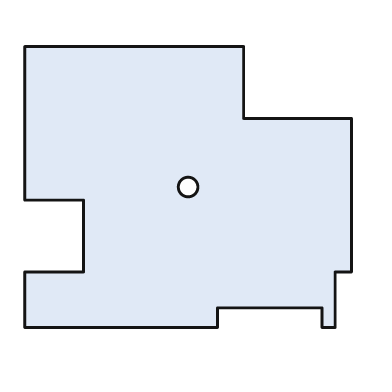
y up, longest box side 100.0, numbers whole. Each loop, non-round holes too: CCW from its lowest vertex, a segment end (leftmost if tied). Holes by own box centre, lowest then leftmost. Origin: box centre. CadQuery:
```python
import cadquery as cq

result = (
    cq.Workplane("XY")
    .moveTo(-50.0, -43.0)
    .lineTo(9.0, -43.0)
    .lineTo(9.0, -37.0)
    .lineTo(41.0, -37.0)
    .lineTo(41.0, -43.0)
    .lineTo(45.0, -43.0)
    .lineTo(45.0, -26.0)
    .lineTo(50.0, -26.0)
    .lineTo(50.0, 21.0)
    .lineTo(17.0, 21.0)
    .lineTo(17.0, 43.0)
    .lineTo(-50.0, 43.0)
    .lineTo(-50.0, -4.0)
    .lineTo(-32.0, -4.0)
    .lineTo(-32.0, -26.0)
    .lineTo(-50.0, -26.0)
    .close()
    .moveTo(0.0, 0.0)
    .circle(3.0)
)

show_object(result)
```